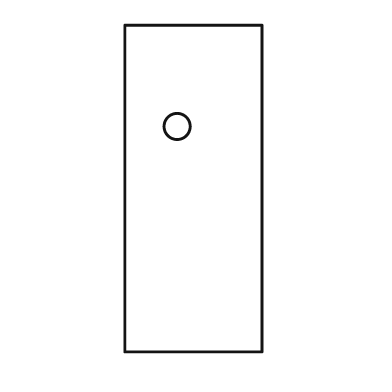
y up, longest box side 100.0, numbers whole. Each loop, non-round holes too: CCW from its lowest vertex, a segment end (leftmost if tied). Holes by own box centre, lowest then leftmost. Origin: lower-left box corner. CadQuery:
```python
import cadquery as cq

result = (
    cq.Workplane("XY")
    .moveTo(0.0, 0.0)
    .lineTo(42.0, 0.0)
    .lineTo(42.0, 100.0)
    .lineTo(0.0, 100.0)
    .close()
    .moveTo(16.0, 69.0)
    .circle(4.0)
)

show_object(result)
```